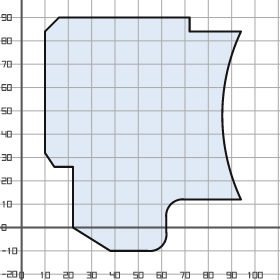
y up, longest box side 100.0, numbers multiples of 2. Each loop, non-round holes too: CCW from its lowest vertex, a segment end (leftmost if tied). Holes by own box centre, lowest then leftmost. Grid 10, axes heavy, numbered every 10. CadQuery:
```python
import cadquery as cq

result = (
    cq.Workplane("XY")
    .moveTo(38.0, -10.0)
    .lineTo(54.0, -10.0)
    .threePointArc((60.0, -8.0), (62.0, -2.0))
    .lineTo(62.0, 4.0)
    .threePointArc((64.0, 10.0), (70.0, 12.0))
    .lineTo(94.0, 12.0)
    .threePointArc((86.0, 48.0), (94.0, 84.0))
    .lineTo(72.0, 84.0)
    .lineTo(72.0, 90.0)
    .lineTo(16.0, 90.0)
    .lineTo(10.0, 84.0)
    .lineTo(10.0, 32.0)
    .lineTo(14.0, 26.0)
    .lineTo(22.0, 26.0)
    .lineTo(22.0, 0.0)
    .close()
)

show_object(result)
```